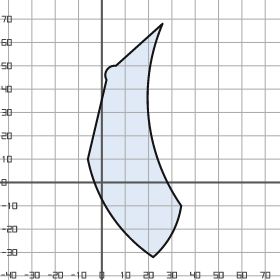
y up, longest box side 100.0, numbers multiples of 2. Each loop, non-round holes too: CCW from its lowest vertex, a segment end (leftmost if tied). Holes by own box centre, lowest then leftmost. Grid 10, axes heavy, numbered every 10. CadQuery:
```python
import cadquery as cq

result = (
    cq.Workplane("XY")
    .moveTo(22.0, -32.0)
    .threePointArc((30.0, -22.0), (34.0, -10.0))
    .threePointArc((20.0, 28.0), (26.0, 68.0))
    .lineTo(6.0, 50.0)
    .threePointArc((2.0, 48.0), (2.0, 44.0))
    .lineTo(-6.0, 10.0)
    .threePointArc((4.0, -14.0), (22.0, -32.0))
    .close()
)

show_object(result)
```